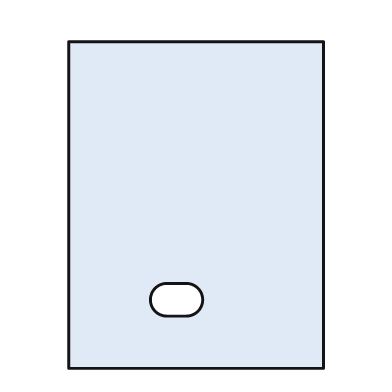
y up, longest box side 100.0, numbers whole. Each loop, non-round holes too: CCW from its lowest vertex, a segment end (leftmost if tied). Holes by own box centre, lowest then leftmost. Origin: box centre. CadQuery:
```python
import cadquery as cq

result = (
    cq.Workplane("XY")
    .moveTo(-39.0, -50.0)
    .lineTo(39.0, -50.0)
    .lineTo(39.0, 50.0)
    .lineTo(-39.0, 50.0)
    .close()
    .moveTo(-9.0, -34.0)
    .lineTo(-3.0, -34.0)
    .threePointArc((2.0, -29.0), (-3.0, -24.0))
    .lineTo(-9.0, -24.0)
    .threePointArc((-14.0, -29.0), (-9.0, -34.0))
    .close()
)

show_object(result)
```